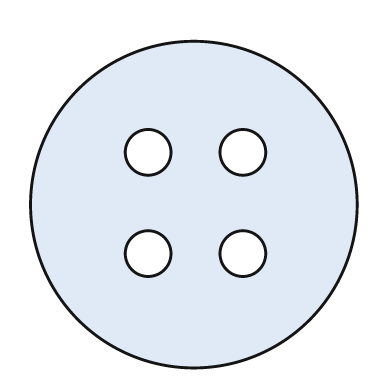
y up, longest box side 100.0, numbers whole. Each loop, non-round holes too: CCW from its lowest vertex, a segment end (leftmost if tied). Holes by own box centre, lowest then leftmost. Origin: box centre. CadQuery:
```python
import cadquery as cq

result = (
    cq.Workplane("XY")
    .moveTo(0.0, 0.0)
    .circle(50.0)
    .moveTo(-14.0, -15.0)
    .circle(7.0)
    .moveTo(15.0, -15.0)
    .circle(7.0)
    .moveTo(-14.0, 16.0)
    .circle(7.0)
    .moveTo(15.0, 16.0)
    .circle(7.0)
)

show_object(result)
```